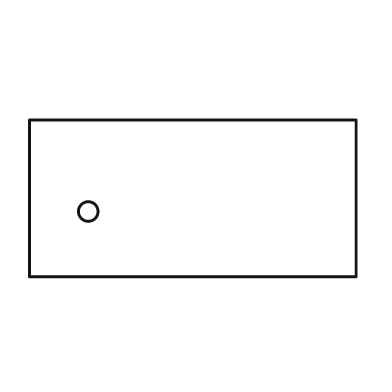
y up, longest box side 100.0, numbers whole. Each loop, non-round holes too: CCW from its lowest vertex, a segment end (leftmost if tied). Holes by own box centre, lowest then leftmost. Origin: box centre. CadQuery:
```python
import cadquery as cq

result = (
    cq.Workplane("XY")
    .moveTo(-50.0, -24.0)
    .lineTo(50.0, -24.0)
    .lineTo(50.0, 24.0)
    .lineTo(-50.0, 24.0)
    .close()
    .moveTo(-32.0, -4.0)
    .circle(3.0)
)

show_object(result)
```